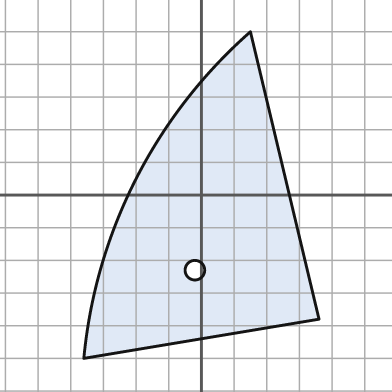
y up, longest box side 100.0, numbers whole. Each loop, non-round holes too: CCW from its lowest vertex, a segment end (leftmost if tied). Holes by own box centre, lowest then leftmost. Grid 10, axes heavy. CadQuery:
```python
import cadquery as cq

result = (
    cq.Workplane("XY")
    .moveTo(-36.0, -50.0)
    .lineTo(36.0, -38.0)
    .lineTo(15.0, 50.0)
    .threePointArc((-20.0, 5.0), (-36.0, -50.0))
    .close()
    .moveTo(-2.0, -23.0)
    .circle(3.0)
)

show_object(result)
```